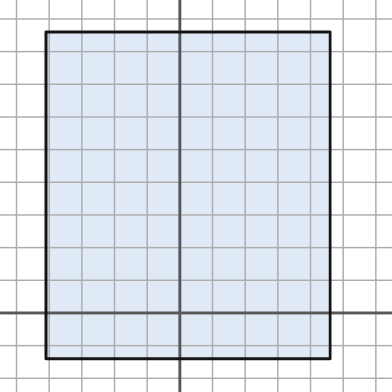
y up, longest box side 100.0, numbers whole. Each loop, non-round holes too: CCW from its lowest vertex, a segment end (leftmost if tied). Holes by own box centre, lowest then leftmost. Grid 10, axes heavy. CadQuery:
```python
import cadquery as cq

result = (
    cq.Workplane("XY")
    .moveTo(-41.0, -14.0)
    .lineTo(46.0, -14.0)
    .lineTo(46.0, 86.0)
    .lineTo(-41.0, 86.0)
    .close()
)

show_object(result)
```